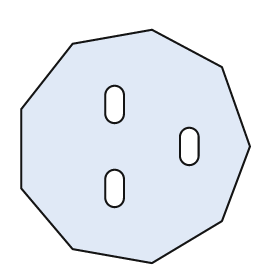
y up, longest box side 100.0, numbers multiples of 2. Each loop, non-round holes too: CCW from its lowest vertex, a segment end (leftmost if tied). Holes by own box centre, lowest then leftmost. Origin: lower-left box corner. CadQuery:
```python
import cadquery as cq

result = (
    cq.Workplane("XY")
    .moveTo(56.0, 0.0)
    .lineTo(86.0, 18.0)
    .lineTo(98.0, 50.0)
    .lineTo(86.0, 84.0)
    .lineTo(56.0, 100.0)
    .lineTo(22.0, 94.0)
    .lineTo(0.0, 66.0)
    .lineTo(0.0, 32.0)
    .lineTo(22.0, 6.0)
    .close()
    .moveTo(36.0, 28.0)
    .threePointArc((40.0, 24.0), (44.0, 28.0))
    .lineTo(44.0, 36.0)
    .threePointArc((40.0, 40.0), (36.0, 36.0))
    .close()
    .moveTo(68.0, 46.0)
    .threePointArc((72.0, 42.0), (76.0, 46.0))
    .lineTo(76.0, 54.0)
    .threePointArc((72.0, 58.0), (68.0, 54.0))
    .close()
    .moveTo(36.0, 64.0)
    .threePointArc((40.0, 60.0), (44.0, 64.0))
    .lineTo(44.0, 72.0)
    .threePointArc((40.0, 76.0), (36.0, 72.0))
    .close()
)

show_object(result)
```